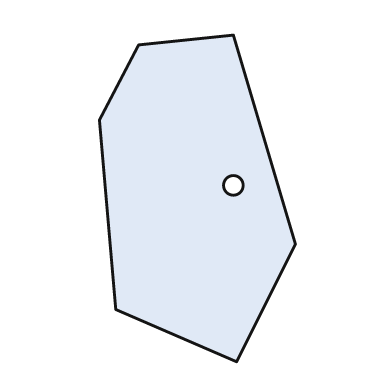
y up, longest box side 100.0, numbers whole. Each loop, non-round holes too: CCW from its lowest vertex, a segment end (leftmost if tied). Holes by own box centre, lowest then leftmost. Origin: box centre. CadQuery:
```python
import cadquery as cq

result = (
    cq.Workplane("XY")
    .moveTo(12.0, -50.0)
    .lineTo(30.0, -14.0)
    .lineTo(11.0, 50.0)
    .lineTo(-18.0, 47.0)
    .lineTo(-30.0, 24.0)
    .lineTo(-25.0, -34.0)
    .close()
    .moveTo(11.0, 4.0)
    .circle(3.0)
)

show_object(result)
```